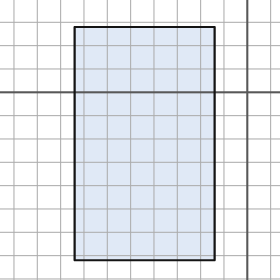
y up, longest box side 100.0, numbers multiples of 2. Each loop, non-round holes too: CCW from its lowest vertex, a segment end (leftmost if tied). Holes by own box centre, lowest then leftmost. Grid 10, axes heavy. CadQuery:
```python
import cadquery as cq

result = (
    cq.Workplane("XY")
    .moveTo(-74.0, -72.0)
    .lineTo(-14.0, -72.0)
    .lineTo(-14.0, 28.0)
    .lineTo(-74.0, 28.0)
    .close()
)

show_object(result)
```